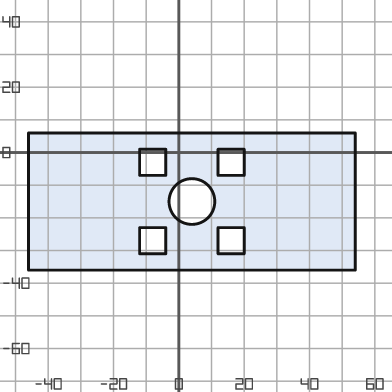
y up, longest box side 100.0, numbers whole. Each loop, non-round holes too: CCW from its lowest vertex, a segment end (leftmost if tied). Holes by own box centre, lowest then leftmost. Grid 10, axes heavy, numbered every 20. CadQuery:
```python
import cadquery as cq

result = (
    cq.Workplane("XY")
    .moveTo(-46.0, -36.0)
    .lineTo(54.0, -36.0)
    .lineTo(54.0, 6.0)
    .lineTo(-46.0, 6.0)
    .close()
    .moveTo(-12.0, -31.0)
    .lineTo(-4.0, -31.0)
    .lineTo(-4.0, -23.0)
    .lineTo(-12.0, -23.0)
    .close()
    .moveTo(12.0, -31.0)
    .lineTo(20.0, -31.0)
    .lineTo(20.0, -23.0)
    .lineTo(12.0, -23.0)
    .close()
    .moveTo(4.0, -15.0)
    .circle(7.0)
    .moveTo(-12.0, -7.0)
    .lineTo(-4.0, -7.0)
    .lineTo(-4.0, 1.0)
    .lineTo(-12.0, 1.0)
    .close()
    .moveTo(12.0, -7.0)
    .lineTo(20.0, -7.0)
    .lineTo(20.0, 1.0)
    .lineTo(12.0, 1.0)
    .close()
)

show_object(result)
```